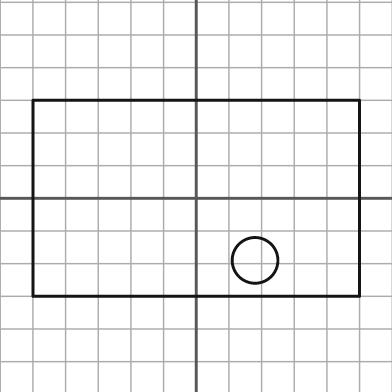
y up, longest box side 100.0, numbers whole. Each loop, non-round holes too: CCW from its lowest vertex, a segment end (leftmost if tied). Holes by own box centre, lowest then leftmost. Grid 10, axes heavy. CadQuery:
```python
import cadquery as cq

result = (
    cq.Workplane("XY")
    .moveTo(-50.0, -30.0)
    .lineTo(50.0, -30.0)
    .lineTo(50.0, 30.0)
    .lineTo(-50.0, 30.0)
    .close()
    .moveTo(18.0, -19.0)
    .circle(7.0)
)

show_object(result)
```